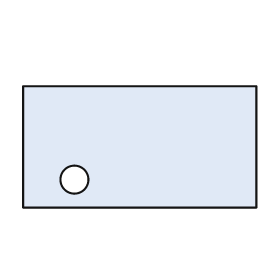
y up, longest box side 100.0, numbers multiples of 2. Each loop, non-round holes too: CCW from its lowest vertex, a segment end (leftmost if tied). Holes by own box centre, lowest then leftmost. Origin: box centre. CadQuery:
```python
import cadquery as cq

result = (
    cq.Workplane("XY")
    .moveTo(-50.0, -26.0)
    .lineTo(50.0, -26.0)
    .lineTo(50.0, 26.0)
    .lineTo(-50.0, 26.0)
    .close()
    .moveTo(-28.0, -14.0)
    .circle(6.0)
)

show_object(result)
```